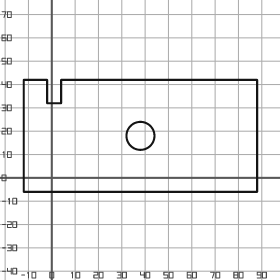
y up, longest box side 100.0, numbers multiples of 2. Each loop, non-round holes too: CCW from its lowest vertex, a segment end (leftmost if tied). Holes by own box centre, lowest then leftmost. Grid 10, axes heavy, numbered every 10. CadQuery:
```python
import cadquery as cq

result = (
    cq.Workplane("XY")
    .moveTo(-12.0, -6.0)
    .lineTo(88.0, -6.0)
    .lineTo(88.0, 42.0)
    .lineTo(4.0, 42.0)
    .lineTo(4.0, 32.0)
    .lineTo(-2.0, 32.0)
    .lineTo(-2.0, 42.0)
    .lineTo(-12.0, 42.0)
    .close()
    .moveTo(38.0, 18.0)
    .circle(6.0)
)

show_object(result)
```